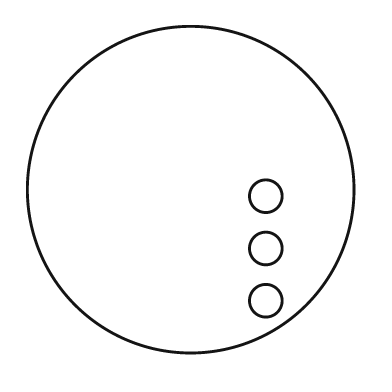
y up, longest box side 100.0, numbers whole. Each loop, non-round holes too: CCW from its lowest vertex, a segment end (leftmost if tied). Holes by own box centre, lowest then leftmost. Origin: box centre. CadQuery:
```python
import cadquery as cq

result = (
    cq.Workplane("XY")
    .moveTo(0.0, 0.0)
    .circle(50.0)
    .moveTo(23.0, -34.0)
    .circle(5.0)
    .moveTo(23.0, -18.0)
    .circle(5.0)
    .moveTo(23.0, -2.0)
    .circle(5.0)
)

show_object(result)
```